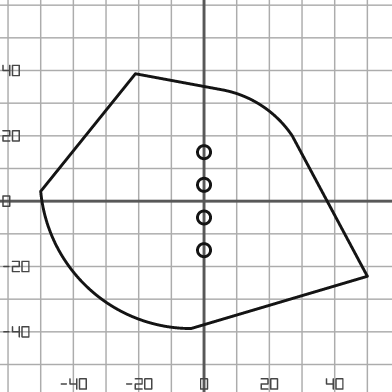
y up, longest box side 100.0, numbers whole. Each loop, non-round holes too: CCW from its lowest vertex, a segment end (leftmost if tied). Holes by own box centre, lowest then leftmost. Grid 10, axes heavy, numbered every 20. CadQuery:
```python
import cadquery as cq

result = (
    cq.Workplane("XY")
    .moveTo(-4.0, -39.0)
    .lineTo(50.0, -23.0)
    .lineTo(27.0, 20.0)
    .threePointArc((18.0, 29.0), (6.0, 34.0))
    .lineTo(-21.0, 39.0)
    .lineTo(-50.0, 3.0)
    .threePointArc((-35.0, -27.0), (-4.0, -39.0))
    .close()
    .moveTo(0.0, -15.0)
    .circle(2.0)
    .moveTo(0.0, -5.0)
    .circle(2.0)
    .moveTo(0.0, 5.0)
    .circle(2.0)
    .moveTo(0.0, 15.0)
    .circle(2.0)
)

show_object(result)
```